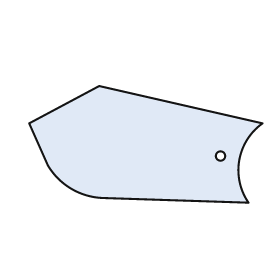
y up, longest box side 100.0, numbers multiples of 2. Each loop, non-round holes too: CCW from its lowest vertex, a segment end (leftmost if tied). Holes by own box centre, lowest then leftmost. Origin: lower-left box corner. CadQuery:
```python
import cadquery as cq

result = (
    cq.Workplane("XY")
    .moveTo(94.0, 0.0)
    .threePointArc((90.0, 18.0), (100.0, 34.0))
    .lineTo(30.0, 50.0)
    .lineTo(0.0, 34.0)
    .lineTo(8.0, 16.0)
    .threePointArc((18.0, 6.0), (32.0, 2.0))
    .close()
    .moveTo(82.0, 20.0)
    .circle(2.0)
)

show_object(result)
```